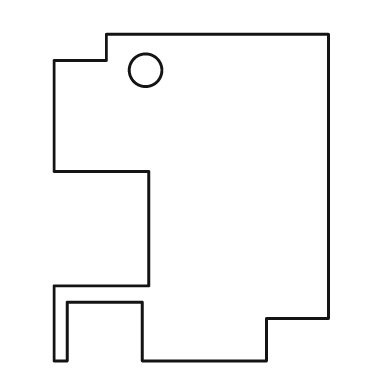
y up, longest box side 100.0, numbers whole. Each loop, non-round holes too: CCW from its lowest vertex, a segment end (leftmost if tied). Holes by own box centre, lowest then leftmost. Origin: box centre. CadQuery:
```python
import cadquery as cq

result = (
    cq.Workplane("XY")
    .moveTo(-42.0, -50.0)
    .lineTo(-38.0, -50.0)
    .lineTo(-38.0, -32.0)
    .lineTo(-15.0, -32.0)
    .lineTo(-15.0, -50.0)
    .lineTo(23.0, -50.0)
    .lineTo(23.0, -37.0)
    .lineTo(42.0, -37.0)
    .lineTo(42.0, 50.0)
    .lineTo(-26.0, 50.0)
    .lineTo(-26.0, 42.0)
    .lineTo(-42.0, 42.0)
    .lineTo(-42.0, 8.0)
    .lineTo(-13.0, 8.0)
    .lineTo(-13.0, -27.0)
    .lineTo(-42.0, -27.0)
    .close()
    .moveTo(-14.0, 39.0)
    .circle(5.0)
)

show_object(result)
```